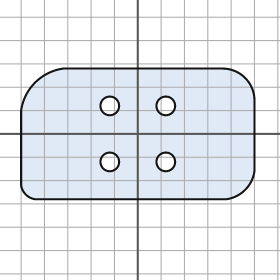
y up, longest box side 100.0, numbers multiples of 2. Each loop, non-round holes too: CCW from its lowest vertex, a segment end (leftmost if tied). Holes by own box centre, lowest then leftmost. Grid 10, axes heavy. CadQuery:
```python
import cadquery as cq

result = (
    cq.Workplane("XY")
    .moveTo(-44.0, -28.0)
    .lineTo(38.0, -28.0)
    .threePointArc((46.0, -24.0), (50.0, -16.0))
    .lineTo(50.0, 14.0)
    .threePointArc((46.0, 24.0), (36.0, 28.0))
    .lineTo(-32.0, 28.0)
    .threePointArc((-44.0, 22.0), (-50.0, 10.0))
    .lineTo(-50.0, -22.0)
    .threePointArc((-48.0, -26.0), (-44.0, -28.0))
    .close()
    .moveTo(-12.0, -12.0)
    .circle(4.0)
    .moveTo(12.0, -12.0)
    .circle(4.0)
    .moveTo(-12.0, 12.0)
    .circle(4.0)
    .moveTo(12.0, 12.0)
    .circle(4.0)
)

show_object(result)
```